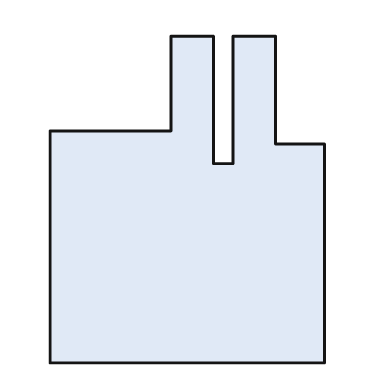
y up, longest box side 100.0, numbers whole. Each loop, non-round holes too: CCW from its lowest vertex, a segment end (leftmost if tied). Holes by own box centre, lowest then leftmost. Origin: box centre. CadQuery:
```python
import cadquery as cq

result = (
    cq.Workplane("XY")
    .moveTo(-42.0, -50.0)
    .lineTo(42.0, -50.0)
    .lineTo(42.0, 17.0)
    .lineTo(27.0, 17.0)
    .lineTo(27.0, 50.0)
    .lineTo(14.0, 50.0)
    .lineTo(14.0, 11.0)
    .lineTo(8.0, 11.0)
    .lineTo(8.0, 50.0)
    .lineTo(-5.0, 50.0)
    .lineTo(-5.0, 21.0)
    .lineTo(-42.0, 21.0)
    .close()
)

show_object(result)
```